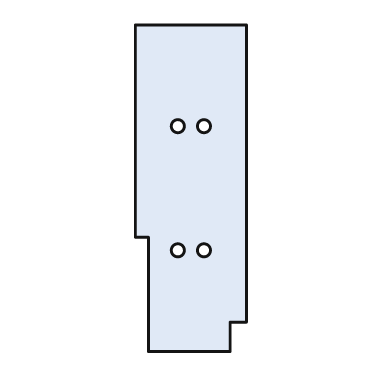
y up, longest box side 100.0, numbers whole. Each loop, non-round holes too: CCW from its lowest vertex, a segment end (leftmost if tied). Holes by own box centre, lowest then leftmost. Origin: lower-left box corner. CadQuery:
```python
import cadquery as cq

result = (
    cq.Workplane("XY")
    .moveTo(4.0, 0.0)
    .lineTo(29.0, 0.0)
    .lineTo(29.0, 9.0)
    .lineTo(34.0, 9.0)
    .lineTo(34.0, 100.0)
    .lineTo(0.0, 100.0)
    .lineTo(0.0, 35.0)
    .lineTo(4.0, 35.0)
    .close()
    .moveTo(13.0, 31.0)
    .circle(2.0)
    .moveTo(21.0, 31.0)
    .circle(2.0)
    .moveTo(13.0, 69.0)
    .circle(2.0)
    .moveTo(21.0, 69.0)
    .circle(2.0)
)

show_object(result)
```